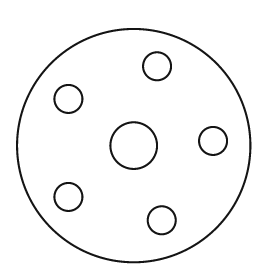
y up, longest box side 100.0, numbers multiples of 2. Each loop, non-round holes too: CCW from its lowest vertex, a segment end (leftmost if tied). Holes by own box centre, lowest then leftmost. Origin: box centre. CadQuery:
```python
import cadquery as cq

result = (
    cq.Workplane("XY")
    .moveTo(0.0, 0.0)
    .circle(50.0)
    .moveTo(12.0, -32.0)
    .circle(6.0)
    .moveTo(-28.0, -22.0)
    .circle(6.0)
    .moveTo(0.0, 0.0)
    .circle(10.0)
    .moveTo(34.0, 2.0)
    .circle(6.0)
    .moveTo(-28.0, 20.0)
    .circle(6.0)
    .moveTo(10.0, 34.0)
    .circle(6.0)
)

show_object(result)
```